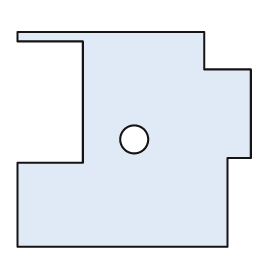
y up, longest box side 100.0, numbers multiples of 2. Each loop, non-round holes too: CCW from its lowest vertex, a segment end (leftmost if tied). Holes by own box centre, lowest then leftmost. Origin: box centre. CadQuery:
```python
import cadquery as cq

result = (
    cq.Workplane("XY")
    .moveTo(-50.0, -46.0)
    .lineTo(40.0, -46.0)
    .lineTo(40.0, -8.0)
    .lineTo(50.0, -8.0)
    .lineTo(50.0, 30.0)
    .lineTo(30.0, 30.0)
    .lineTo(30.0, 46.0)
    .lineTo(-50.0, 46.0)
    .lineTo(-50.0, 42.0)
    .lineTo(-22.0, 42.0)
    .lineTo(-22.0, -10.0)
    .lineTo(-50.0, -10.0)
    .close()
    .moveTo(0.0, 0.0)
    .circle(6.0)
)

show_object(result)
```